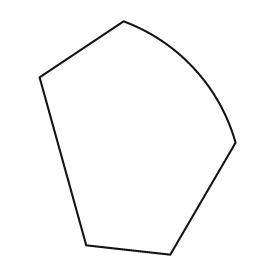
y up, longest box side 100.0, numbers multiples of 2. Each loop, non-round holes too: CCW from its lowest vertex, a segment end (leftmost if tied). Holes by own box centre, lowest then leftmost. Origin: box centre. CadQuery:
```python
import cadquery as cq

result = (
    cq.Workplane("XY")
    .moveTo(14.0, -50.0)
    .lineTo(42.0, -2.0)
    .threePointArc((24.0, 30.0), (-6.0, 50.0))
    .lineTo(-42.0, 26.0)
    .lineTo(-22.0, -46.0)
    .close()
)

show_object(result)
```